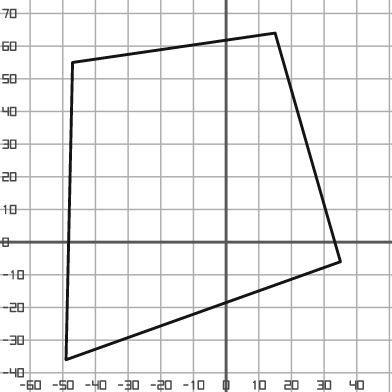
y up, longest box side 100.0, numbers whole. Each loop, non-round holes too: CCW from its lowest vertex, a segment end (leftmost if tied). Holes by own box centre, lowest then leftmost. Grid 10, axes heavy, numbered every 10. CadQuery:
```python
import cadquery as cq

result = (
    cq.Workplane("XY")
    .moveTo(-49.0, -36.0)
    .lineTo(35.0, -6.0)
    .lineTo(15.0, 64.0)
    .lineTo(-47.0, 55.0)
    .close()
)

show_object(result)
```